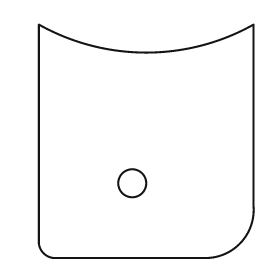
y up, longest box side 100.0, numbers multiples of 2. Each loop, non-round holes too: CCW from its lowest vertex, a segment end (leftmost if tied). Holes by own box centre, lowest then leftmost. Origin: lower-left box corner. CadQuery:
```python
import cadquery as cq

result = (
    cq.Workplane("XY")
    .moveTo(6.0, 0.0)
    .lineTo(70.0, 0.0)
    .threePointArc((86.0, 6.0), (92.0, 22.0))
    .lineTo(92.0, 100.0)
    .threePointArc((46.0, 88.0), (0.0, 100.0))
    .lineTo(0.0, 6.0)
    .threePointArc((2.0, 2.0), (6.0, 0.0))
    .close()
    .moveTo(40.0, 32.0)
    .circle(6.0)
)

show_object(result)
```